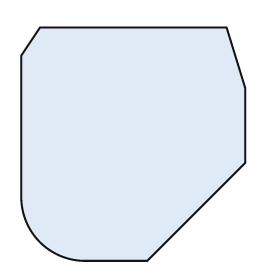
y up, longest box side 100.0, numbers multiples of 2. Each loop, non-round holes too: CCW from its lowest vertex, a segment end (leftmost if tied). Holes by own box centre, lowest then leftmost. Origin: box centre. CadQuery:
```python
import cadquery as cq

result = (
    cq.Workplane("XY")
    .moveTo(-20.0, -50.0)
    .lineTo(6.0, -50.0)
    .lineTo(48.0, -8.0)
    .lineTo(48.0, 24.0)
    .lineTo(40.0, 50.0)
    .lineTo(-40.0, 50.0)
    .lineTo(-48.0, 38.0)
    .lineTo(-48.0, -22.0)
    .threePointArc((-40.0, -42.0), (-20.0, -50.0))
    .close()
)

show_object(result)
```